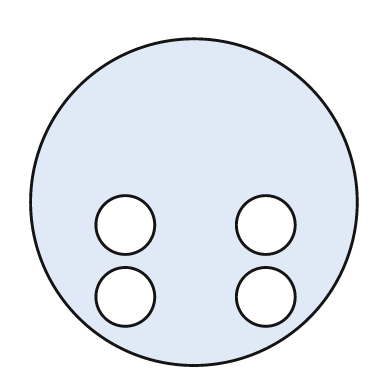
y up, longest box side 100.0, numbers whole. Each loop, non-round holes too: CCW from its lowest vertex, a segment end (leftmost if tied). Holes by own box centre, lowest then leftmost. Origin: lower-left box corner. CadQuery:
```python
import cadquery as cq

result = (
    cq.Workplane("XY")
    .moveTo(50.0, 50.0)
    .circle(50.0)
    .moveTo(29.0, 21.0)
    .circle(9.0)
    .moveTo(72.0, 21.0)
    .circle(9.0)
    .moveTo(29.0, 43.0)
    .circle(9.0)
    .moveTo(72.0, 43.0)
    .circle(9.0)
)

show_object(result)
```